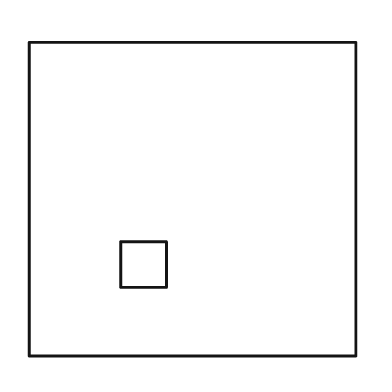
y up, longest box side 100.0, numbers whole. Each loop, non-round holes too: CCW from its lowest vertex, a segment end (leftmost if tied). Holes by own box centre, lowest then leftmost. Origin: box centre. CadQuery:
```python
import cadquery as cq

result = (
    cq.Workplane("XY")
    .moveTo(-50.0, -48.0)
    .lineTo(50.0, -48.0)
    .lineTo(50.0, 48.0)
    .lineTo(-50.0, 48.0)
    .close()
    .moveTo(-22.0, -27.0)
    .lineTo(-8.0, -27.0)
    .lineTo(-8.0, -13.0)
    .lineTo(-22.0, -13.0)
    .close()
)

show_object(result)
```